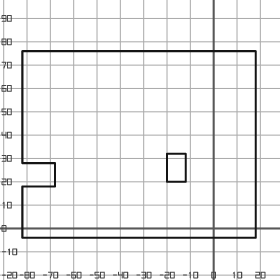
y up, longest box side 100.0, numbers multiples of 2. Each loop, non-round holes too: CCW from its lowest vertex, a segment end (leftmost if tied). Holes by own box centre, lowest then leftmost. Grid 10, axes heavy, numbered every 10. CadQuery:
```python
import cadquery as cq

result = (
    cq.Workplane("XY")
    .moveTo(-82.0, -4.0)
    .lineTo(18.0, -4.0)
    .lineTo(18.0, 76.0)
    .lineTo(-82.0, 76.0)
    .lineTo(-82.0, 28.0)
    .lineTo(-68.0, 28.0)
    .lineTo(-68.0, 18.0)
    .lineTo(-82.0, 18.0)
    .close()
    .moveTo(-20.0, 20.0)
    .lineTo(-12.0, 20.0)
    .lineTo(-12.0, 32.0)
    .lineTo(-20.0, 32.0)
    .close()
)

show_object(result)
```